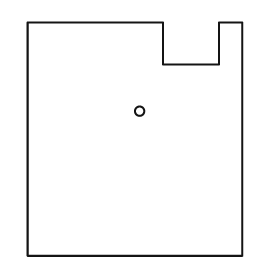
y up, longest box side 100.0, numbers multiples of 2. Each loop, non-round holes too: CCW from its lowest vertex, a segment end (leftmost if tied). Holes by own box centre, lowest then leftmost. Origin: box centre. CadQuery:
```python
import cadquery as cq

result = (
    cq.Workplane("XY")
    .moveTo(-46.0, -50.0)
    .lineTo(46.0, -50.0)
    .lineTo(46.0, 50.0)
    .lineTo(36.0, 50.0)
    .lineTo(36.0, 32.0)
    .lineTo(12.0, 32.0)
    .lineTo(12.0, 50.0)
    .lineTo(-46.0, 50.0)
    .close()
    .moveTo(2.0, 12.0)
    .circle(2.0)
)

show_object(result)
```